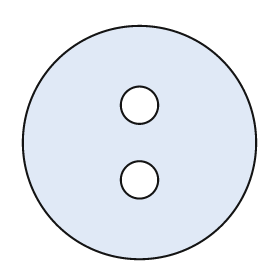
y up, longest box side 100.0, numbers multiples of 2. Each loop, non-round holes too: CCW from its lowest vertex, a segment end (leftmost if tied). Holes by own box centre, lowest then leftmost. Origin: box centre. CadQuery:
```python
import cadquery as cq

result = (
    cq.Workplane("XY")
    .moveTo(0.0, 0.0)
    .circle(50.0)
    .moveTo(0.0, -16.0)
    .circle(8.0)
    .moveTo(0.0, 16.0)
    .circle(8.0)
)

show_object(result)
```